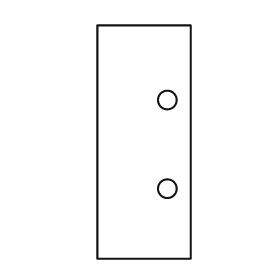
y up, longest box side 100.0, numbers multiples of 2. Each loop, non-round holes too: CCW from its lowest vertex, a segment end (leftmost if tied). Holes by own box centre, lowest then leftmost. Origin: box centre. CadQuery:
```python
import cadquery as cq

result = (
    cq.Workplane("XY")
    .moveTo(-20.0, -50.0)
    .lineTo(20.0, -50.0)
    .lineTo(20.0, 50.0)
    .lineTo(-20.0, 50.0)
    .close()
    .moveTo(10.0, -20.0)
    .circle(4.0)
    .moveTo(10.0, 18.0)
    .circle(4.0)
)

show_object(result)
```